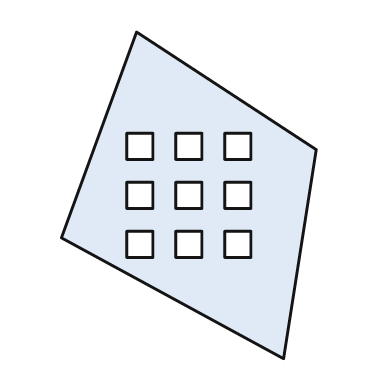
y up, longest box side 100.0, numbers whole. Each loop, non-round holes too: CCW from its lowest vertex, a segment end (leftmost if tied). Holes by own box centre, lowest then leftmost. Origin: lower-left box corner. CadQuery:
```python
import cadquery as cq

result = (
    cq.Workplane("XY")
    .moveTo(68.0, 0.0)
    .lineTo(78.0, 64.0)
    .lineTo(23.0, 100.0)
    .lineTo(0.0, 37.0)
    .close()
    .moveTo(20.0, 31.0)
    .lineTo(28.0, 31.0)
    .lineTo(28.0, 39.0)
    .lineTo(20.0, 39.0)
    .close()
    .moveTo(35.0, 31.0)
    .lineTo(43.0, 31.0)
    .lineTo(43.0, 39.0)
    .lineTo(35.0, 39.0)
    .close()
    .moveTo(50.0, 31.0)
    .lineTo(58.0, 31.0)
    .lineTo(58.0, 39.0)
    .lineTo(50.0, 39.0)
    .close()
    .moveTo(20.0, 46.0)
    .lineTo(28.0, 46.0)
    .lineTo(28.0, 54.0)
    .lineTo(20.0, 54.0)
    .close()
    .moveTo(35.0, 46.0)
    .lineTo(43.0, 46.0)
    .lineTo(43.0, 54.0)
    .lineTo(35.0, 54.0)
    .close()
    .moveTo(50.0, 46.0)
    .lineTo(58.0, 46.0)
    .lineTo(58.0, 54.0)
    .lineTo(50.0, 54.0)
    .close()
    .moveTo(20.0, 61.0)
    .lineTo(28.0, 61.0)
    .lineTo(28.0, 69.0)
    .lineTo(20.0, 69.0)
    .close()
    .moveTo(35.0, 61.0)
    .lineTo(43.0, 61.0)
    .lineTo(43.0, 69.0)
    .lineTo(35.0, 69.0)
    .close()
    .moveTo(50.0, 61.0)
    .lineTo(58.0, 61.0)
    .lineTo(58.0, 69.0)
    .lineTo(50.0, 69.0)
    .close()
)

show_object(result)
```